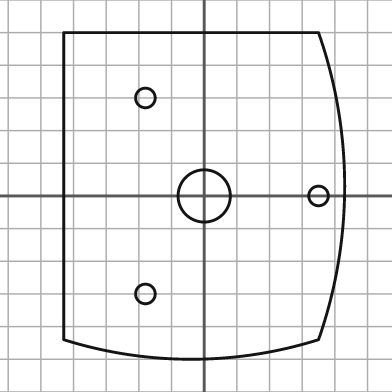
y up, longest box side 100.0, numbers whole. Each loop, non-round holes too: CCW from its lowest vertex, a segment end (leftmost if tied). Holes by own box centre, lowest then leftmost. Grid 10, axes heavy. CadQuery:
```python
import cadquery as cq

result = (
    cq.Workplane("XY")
    .moveTo(-43.0, -44.0)
    .threePointArc((-4.0, -50.0), (35.0, -44.0))
    .threePointArc((43.0, 3.0), (35.0, 50.0))
    .lineTo(-43.0, 50.0)
    .close()
    .moveTo(-18.0, -30.0)
    .circle(3.0)
    .moveTo(0.0, 0.0)
    .circle(8.0)
    .moveTo(35.0, 0.0)
    .circle(3.0)
    .moveTo(-18.0, 30.0)
    .circle(3.0)
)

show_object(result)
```